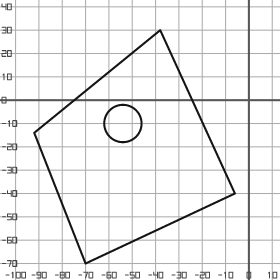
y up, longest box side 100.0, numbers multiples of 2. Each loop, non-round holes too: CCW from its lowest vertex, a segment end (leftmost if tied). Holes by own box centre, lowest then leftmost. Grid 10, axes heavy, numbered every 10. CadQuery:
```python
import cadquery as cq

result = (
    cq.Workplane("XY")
    .moveTo(-70.0, -70.0)
    .lineTo(-6.0, -40.0)
    .lineTo(-38.0, 30.0)
    .lineTo(-92.0, -14.0)
    .close()
    .moveTo(-54.0, -10.0)
    .circle(8.0)
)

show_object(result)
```